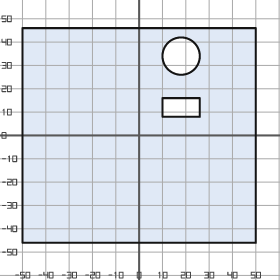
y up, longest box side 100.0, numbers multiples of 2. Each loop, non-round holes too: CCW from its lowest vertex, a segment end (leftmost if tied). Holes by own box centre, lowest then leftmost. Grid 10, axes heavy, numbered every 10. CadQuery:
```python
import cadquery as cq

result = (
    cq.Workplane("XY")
    .moveTo(-50.0, -46.0)
    .lineTo(50.0, -46.0)
    .lineTo(50.0, 46.0)
    .lineTo(-50.0, 46.0)
    .close()
    .moveTo(10.0, 8.0)
    .lineTo(26.0, 8.0)
    .lineTo(26.0, 16.0)
    .lineTo(10.0, 16.0)
    .close()
    .moveTo(18.0, 34.0)
    .circle(8.0)
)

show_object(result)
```